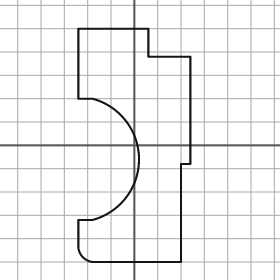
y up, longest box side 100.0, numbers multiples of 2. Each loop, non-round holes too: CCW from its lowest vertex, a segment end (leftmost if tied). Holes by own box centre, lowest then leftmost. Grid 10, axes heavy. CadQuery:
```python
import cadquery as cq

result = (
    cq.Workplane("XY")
    .moveTo(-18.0, -50.0)
    .lineTo(20.0, -50.0)
    .lineTo(20.0, -8.0)
    .lineTo(24.0, -8.0)
    .lineTo(24.0, 38.0)
    .lineTo(6.0, 38.0)
    .lineTo(6.0, 50.0)
    .lineTo(-24.0, 50.0)
    .lineTo(-24.0, 20.0)
    .lineTo(-18.0, 20.0)
    .threePointArc((2.0, -6.0), (-18.0, -32.0))
    .lineTo(-24.0, -32.0)
    .lineTo(-24.0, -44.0)
    .threePointArc((-22.0, -48.0), (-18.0, -50.0))
    .close()
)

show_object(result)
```